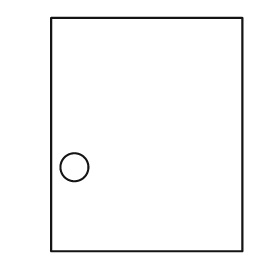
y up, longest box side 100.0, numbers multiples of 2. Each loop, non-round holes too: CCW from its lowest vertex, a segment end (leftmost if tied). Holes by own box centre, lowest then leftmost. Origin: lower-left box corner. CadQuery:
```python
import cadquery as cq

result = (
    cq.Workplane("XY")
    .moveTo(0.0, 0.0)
    .lineTo(82.0, 0.0)
    .lineTo(82.0, 100.0)
    .lineTo(0.0, 100.0)
    .close()
    .moveTo(10.0, 36.0)
    .circle(6.0)
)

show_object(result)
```